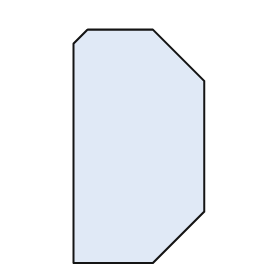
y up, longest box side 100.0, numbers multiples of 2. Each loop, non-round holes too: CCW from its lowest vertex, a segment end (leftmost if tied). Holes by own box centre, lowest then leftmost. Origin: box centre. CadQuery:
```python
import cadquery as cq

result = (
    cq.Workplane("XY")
    .moveTo(-28.0, -50.0)
    .lineTo(6.0, -50.0)
    .lineTo(28.0, -28.0)
    .lineTo(28.0, 28.0)
    .lineTo(6.0, 50.0)
    .lineTo(-22.0, 50.0)
    .lineTo(-28.0, 44.0)
    .close()
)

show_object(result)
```